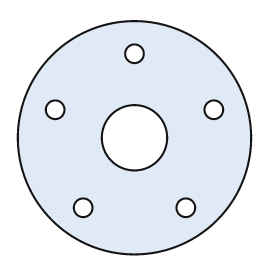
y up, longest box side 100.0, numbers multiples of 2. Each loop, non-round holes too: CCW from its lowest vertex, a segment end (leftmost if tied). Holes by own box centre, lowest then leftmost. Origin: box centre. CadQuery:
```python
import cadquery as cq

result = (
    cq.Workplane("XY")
    .moveTo(0.0, 0.0)
    .circle(50.0)
    .moveTo(-22.0, -30.0)
    .circle(4.0)
    .moveTo(22.0, -30.0)
    .circle(4.0)
    .moveTo(0.0, 0.0)
    .circle(14.0)
    .moveTo(-34.0, 12.0)
    .circle(4.0)
    .moveTo(34.0, 12.0)
    .circle(4.0)
    .moveTo(0.0, 36.0)
    .circle(4.0)
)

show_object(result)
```